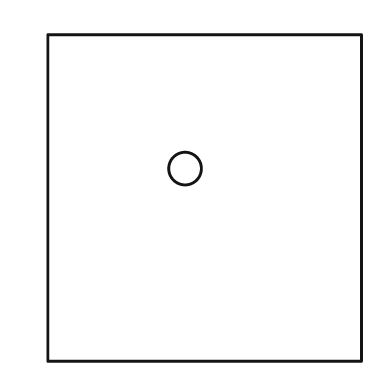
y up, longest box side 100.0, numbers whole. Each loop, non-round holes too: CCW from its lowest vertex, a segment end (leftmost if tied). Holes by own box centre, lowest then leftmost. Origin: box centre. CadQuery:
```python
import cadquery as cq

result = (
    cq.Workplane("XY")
    .moveTo(-48.0, -50.0)
    .lineTo(48.0, -50.0)
    .lineTo(48.0, 50.0)
    .lineTo(-48.0, 50.0)
    .close()
    .moveTo(-6.0, 9.0)
    .circle(5.0)
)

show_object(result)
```